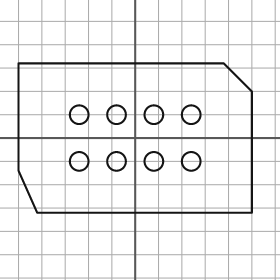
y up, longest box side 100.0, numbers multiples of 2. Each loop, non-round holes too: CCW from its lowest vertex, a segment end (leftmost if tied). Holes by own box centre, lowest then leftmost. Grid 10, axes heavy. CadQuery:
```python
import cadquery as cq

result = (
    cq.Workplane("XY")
    .moveTo(-42.0, -32.0)
    .lineTo(50.0, -32.0)
    .lineTo(50.0, 20.0)
    .lineTo(38.0, 32.0)
    .lineTo(-50.0, 32.0)
    .lineTo(-50.0, -14.0)
    .close()
    .moveTo(-24.0, -10.0)
    .circle(4.0)
    .moveTo(-8.0, -10.0)
    .circle(4.0)
    .moveTo(8.0, -10.0)
    .circle(4.0)
    .moveTo(24.0, -10.0)
    .circle(4.0)
    .moveTo(-24.0, 10.0)
    .circle(4.0)
    .moveTo(-8.0, 10.0)
    .circle(4.0)
    .moveTo(8.0, 10.0)
    .circle(4.0)
    .moveTo(24.0, 10.0)
    .circle(4.0)
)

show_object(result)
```